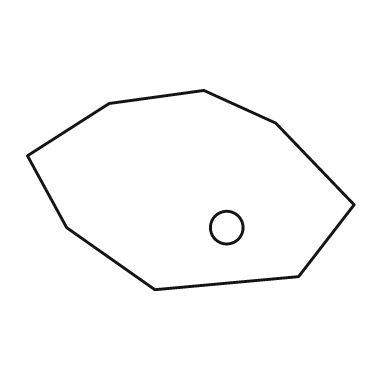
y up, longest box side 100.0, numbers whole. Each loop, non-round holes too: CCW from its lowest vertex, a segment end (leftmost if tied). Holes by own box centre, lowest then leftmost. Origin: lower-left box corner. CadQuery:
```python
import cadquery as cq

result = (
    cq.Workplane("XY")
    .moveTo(39.0, 0.0)
    .lineTo(83.0, 4.0)
    .lineTo(100.0, 26.0)
    .lineTo(76.0, 51.0)
    .lineTo(54.0, 61.0)
    .lineTo(25.0, 57.0)
    .lineTo(0.0, 41.0)
    .lineTo(12.0, 19.0)
    .close()
    .moveTo(61.0, 19.0)
    .circle(5.0)
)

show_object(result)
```